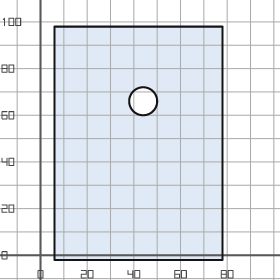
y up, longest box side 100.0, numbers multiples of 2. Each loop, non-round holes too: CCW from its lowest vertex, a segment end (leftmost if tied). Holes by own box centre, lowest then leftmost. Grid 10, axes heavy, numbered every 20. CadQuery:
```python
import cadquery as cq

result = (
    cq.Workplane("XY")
    .moveTo(6.0, -2.0)
    .lineTo(78.0, -2.0)
    .lineTo(78.0, 98.0)
    .lineTo(6.0, 98.0)
    .close()
    .moveTo(44.0, 66.0)
    .circle(6.0)
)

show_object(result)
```